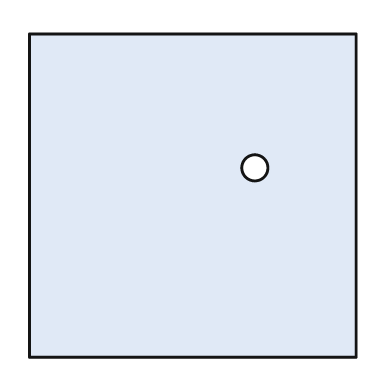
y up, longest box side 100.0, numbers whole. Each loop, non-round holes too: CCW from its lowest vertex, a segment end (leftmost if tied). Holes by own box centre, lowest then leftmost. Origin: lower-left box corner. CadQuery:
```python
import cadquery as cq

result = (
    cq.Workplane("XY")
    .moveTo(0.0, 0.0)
    .lineTo(100.0, 0.0)
    .lineTo(100.0, 99.0)
    .lineTo(0.0, 99.0)
    .close()
    .moveTo(69.0, 58.0)
    .circle(4.0)
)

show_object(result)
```